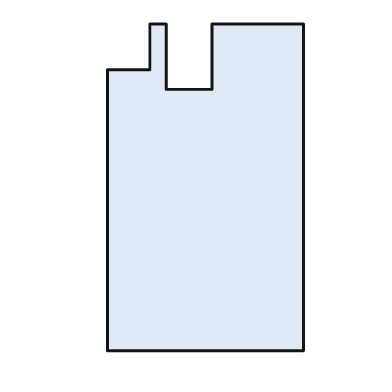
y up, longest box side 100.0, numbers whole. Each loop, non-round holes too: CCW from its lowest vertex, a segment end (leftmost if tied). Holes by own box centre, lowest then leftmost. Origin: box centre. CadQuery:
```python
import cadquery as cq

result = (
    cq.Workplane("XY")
    .moveTo(-30.0, -50.0)
    .lineTo(30.0, -50.0)
    .lineTo(30.0, 50.0)
    .lineTo(2.0, 50.0)
    .lineTo(2.0, 30.0)
    .lineTo(-12.0, 30.0)
    .lineTo(-12.0, 50.0)
    .lineTo(-17.0, 50.0)
    .lineTo(-17.0, 36.0)
    .lineTo(-30.0, 36.0)
    .close()
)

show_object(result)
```